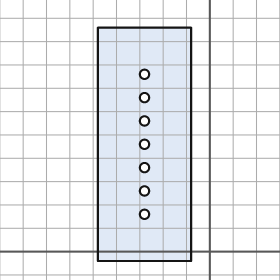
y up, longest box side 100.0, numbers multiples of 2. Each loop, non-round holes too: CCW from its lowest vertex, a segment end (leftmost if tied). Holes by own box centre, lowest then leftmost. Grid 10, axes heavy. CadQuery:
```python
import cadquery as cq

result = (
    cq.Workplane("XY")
    .moveTo(-48.0, -4.0)
    .lineTo(-8.0, -4.0)
    .lineTo(-8.0, 96.0)
    .lineTo(-48.0, 96.0)
    .close()
    .moveTo(-28.0, 16.0)
    .circle(2.0)
    .moveTo(-28.0, 26.0)
    .circle(2.0)
    .moveTo(-28.0, 36.0)
    .circle(2.0)
    .moveTo(-28.0, 46.0)
    .circle(2.0)
    .moveTo(-28.0, 56.0)
    .circle(2.0)
    .moveTo(-28.0, 66.0)
    .circle(2.0)
    .moveTo(-28.0, 76.0)
    .circle(2.0)
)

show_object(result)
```